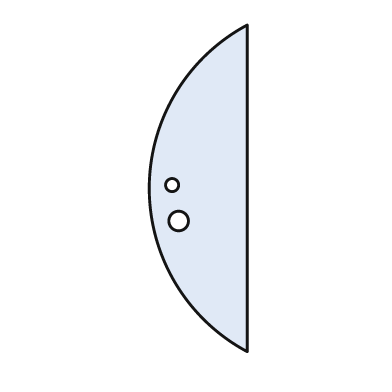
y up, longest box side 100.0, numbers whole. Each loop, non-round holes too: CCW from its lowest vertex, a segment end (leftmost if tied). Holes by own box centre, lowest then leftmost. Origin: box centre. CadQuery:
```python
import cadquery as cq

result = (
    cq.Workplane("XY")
    .moveTo(15.0, -50.0)
    .lineTo(15.0, 50.0)
    .threePointArc((-15.0, 0.0), (15.0, -50.0))
    .close()
    .moveTo(-6.0, -10.0)
    .circle(3.0)
    .moveTo(-8.0, 1.0)
    .circle(2.0)
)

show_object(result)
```